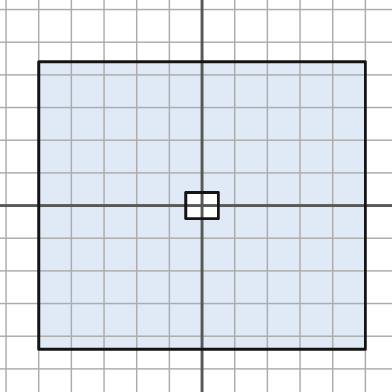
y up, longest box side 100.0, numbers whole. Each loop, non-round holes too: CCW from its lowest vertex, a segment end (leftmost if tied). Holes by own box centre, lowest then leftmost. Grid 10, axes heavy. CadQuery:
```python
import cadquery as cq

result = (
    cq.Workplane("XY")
    .moveTo(-50.0, -44.0)
    .lineTo(50.0, -44.0)
    .lineTo(50.0, 44.0)
    .lineTo(-50.0, 44.0)
    .close()
    .moveTo(-5.0, -4.0)
    .lineTo(5.0, -4.0)
    .lineTo(5.0, 4.0)
    .lineTo(-5.0, 4.0)
    .close()
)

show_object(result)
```